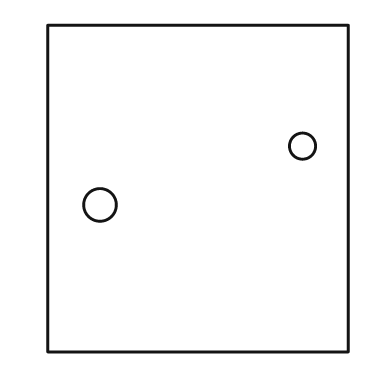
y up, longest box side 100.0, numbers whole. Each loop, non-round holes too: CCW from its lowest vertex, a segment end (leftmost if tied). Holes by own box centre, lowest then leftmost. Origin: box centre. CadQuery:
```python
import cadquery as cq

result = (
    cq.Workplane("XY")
    .moveTo(-46.0, -50.0)
    .lineTo(46.0, -50.0)
    .lineTo(46.0, 50.0)
    .lineTo(-46.0, 50.0)
    .close()
    .moveTo(-30.0, -5.0)
    .circle(5.0)
    .moveTo(32.0, 13.0)
    .circle(4.0)
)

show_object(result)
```